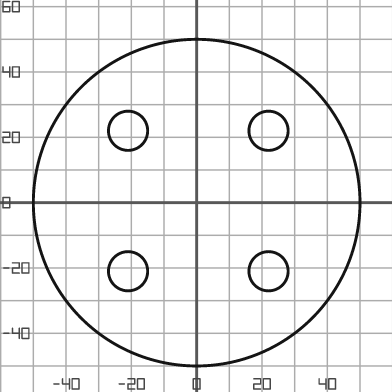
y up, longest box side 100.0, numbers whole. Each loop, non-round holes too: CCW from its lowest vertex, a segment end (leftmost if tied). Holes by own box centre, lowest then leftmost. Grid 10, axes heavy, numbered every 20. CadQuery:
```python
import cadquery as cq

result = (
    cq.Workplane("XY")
    .moveTo(0.0, 0.0)
    .circle(50.0)
    .moveTo(-21.0, -21.0)
    .circle(6.0)
    .moveTo(22.0, -21.0)
    .circle(6.0)
    .moveTo(-21.0, 22.0)
    .circle(6.0)
    .moveTo(22.0, 22.0)
    .circle(6.0)
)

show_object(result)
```